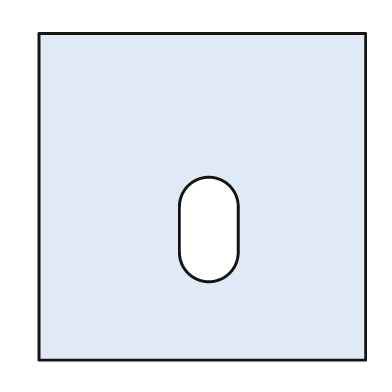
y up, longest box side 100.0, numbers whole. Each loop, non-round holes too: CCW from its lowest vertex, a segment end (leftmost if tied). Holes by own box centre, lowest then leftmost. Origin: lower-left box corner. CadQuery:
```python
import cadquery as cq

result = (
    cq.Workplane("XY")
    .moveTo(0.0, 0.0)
    .lineTo(100.0, 0.0)
    .lineTo(100.0, 100.0)
    .lineTo(0.0, 100.0)
    .close()
    .moveTo(43.0, 33.0)
    .threePointArc((52.0, 24.0), (61.0, 33.0))
    .lineTo(61.0, 47.0)
    .threePointArc((52.0, 56.0), (43.0, 47.0))
    .close()
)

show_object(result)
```